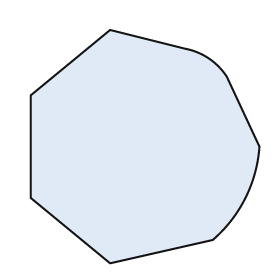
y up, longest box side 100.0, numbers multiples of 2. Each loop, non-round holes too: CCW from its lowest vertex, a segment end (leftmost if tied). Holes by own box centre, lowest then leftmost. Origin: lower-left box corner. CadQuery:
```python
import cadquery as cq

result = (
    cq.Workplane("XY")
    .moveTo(34.0, 0.0)
    .lineTo(78.0, 10.0)
    .threePointArc((92.0, 28.0), (98.0, 50.0))
    .lineTo(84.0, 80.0)
    .threePointArc((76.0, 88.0), (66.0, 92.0))
    .lineTo(34.0, 100.0)
    .lineTo(0.0, 72.0)
    .lineTo(0.0, 28.0)
    .close()
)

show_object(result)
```